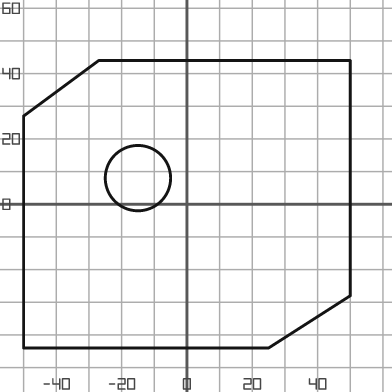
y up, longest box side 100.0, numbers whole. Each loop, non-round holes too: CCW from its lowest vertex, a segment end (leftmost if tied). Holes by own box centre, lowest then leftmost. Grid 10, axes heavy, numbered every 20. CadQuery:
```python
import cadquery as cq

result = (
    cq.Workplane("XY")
    .moveTo(-50.0, -44.0)
    .lineTo(25.0, -44.0)
    .lineTo(50.0, -28.0)
    .lineTo(50.0, 44.0)
    .lineTo(-27.0, 44.0)
    .lineTo(-50.0, 27.0)
    .close()
    .moveTo(-15.0, 8.0)
    .circle(10.0)
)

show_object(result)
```